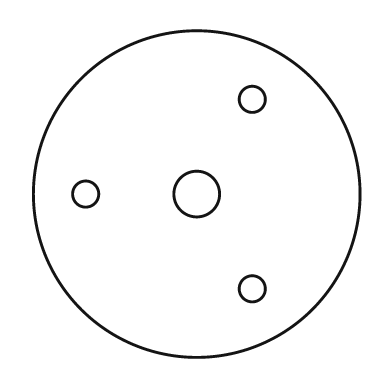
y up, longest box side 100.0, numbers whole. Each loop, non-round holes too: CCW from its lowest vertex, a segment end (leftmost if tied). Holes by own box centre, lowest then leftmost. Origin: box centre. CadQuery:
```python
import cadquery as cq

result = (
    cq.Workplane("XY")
    .moveTo(0.0, 0.0)
    .circle(50.0)
    .moveTo(17.0, -29.0)
    .circle(4.0)
    .moveTo(-34.0, 0.0)
    .circle(4.0)
    .moveTo(0.0, 0.0)
    .circle(7.0)
    .moveTo(17.0, 29.0)
    .circle(4.0)
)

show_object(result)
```